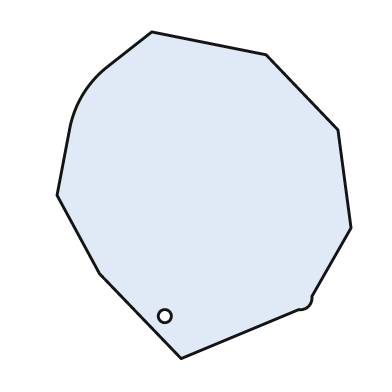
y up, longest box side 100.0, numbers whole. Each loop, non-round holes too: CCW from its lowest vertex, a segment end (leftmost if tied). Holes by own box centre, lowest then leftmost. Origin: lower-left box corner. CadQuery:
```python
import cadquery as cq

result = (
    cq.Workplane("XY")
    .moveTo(38.0, 0.0)
    .lineTo(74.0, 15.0)
    .threePointArc((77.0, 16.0), (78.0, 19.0))
    .lineTo(90.0, 40.0)
    .lineTo(86.0, 70.0)
    .lineTo(64.0, 93.0)
    .lineTo(29.0, 100.0)
    .lineTo(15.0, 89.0)
    .threePointArc((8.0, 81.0), (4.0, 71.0))
    .lineTo(0.0, 50.0)
    .lineTo(13.0, 26.0)
    .close()
    .moveTo(33.0, 13.0)
    .circle(2.0)
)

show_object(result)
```